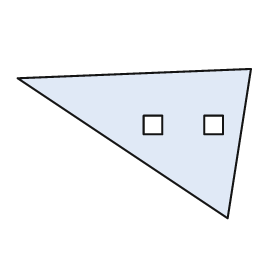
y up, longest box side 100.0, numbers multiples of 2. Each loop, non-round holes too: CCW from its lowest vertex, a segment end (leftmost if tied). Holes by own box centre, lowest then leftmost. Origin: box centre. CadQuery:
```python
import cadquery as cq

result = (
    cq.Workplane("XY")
    .moveTo(40.0, -32.0)
    .lineTo(50.0, 32.0)
    .lineTo(-50.0, 28.0)
    .close()
    .moveTo(4.0, 4.0)
    .lineTo(12.0, 4.0)
    .lineTo(12.0, 12.0)
    .lineTo(4.0, 12.0)
    .close()
    .moveTo(30.0, 4.0)
    .lineTo(38.0, 4.0)
    .lineTo(38.0, 12.0)
    .lineTo(30.0, 12.0)
    .close()
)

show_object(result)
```